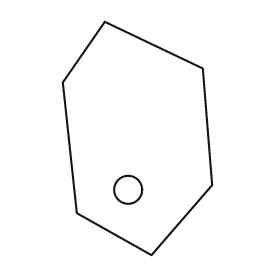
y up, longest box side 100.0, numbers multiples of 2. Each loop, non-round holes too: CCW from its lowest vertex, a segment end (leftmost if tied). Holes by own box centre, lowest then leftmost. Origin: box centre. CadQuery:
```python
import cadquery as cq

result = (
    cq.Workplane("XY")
    .moveTo(6.0, -50.0)
    .lineTo(32.0, -20.0)
    .lineTo(28.0, 30.0)
    .lineTo(-14.0, 50.0)
    .lineTo(-32.0, 24.0)
    .lineTo(-26.0, -32.0)
    .close()
    .moveTo(-4.0, -22.0)
    .circle(6.0)
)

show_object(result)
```